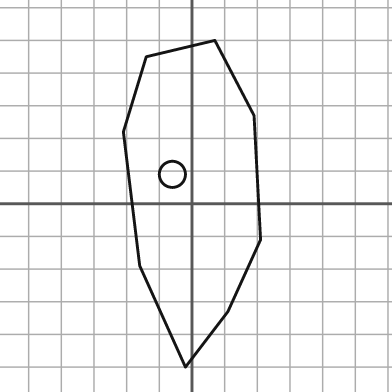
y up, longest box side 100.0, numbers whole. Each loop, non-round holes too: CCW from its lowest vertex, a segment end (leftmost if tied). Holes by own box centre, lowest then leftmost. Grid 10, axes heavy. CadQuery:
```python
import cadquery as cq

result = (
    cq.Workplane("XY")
    .moveTo(-2.0, -50.0)
    .lineTo(11.0, -33.0)
    .lineTo(21.0, -11.0)
    .lineTo(19.0, 27.0)
    .lineTo(7.0, 50.0)
    .lineTo(-14.0, 45.0)
    .lineTo(-21.0, 22.0)
    .lineTo(-16.0, -19.0)
    .close()
    .moveTo(-6.0, 9.0)
    .circle(4.0)
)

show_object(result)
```